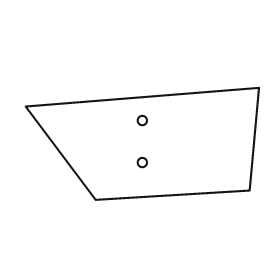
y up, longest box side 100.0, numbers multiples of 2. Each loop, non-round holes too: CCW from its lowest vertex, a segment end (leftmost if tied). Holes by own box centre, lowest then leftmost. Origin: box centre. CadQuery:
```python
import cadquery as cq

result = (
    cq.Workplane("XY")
    .moveTo(-20.0, -24.0)
    .lineTo(46.0, -20.0)
    .lineTo(50.0, 24.0)
    .lineTo(-50.0, 16.0)
    .close()
    .moveTo(0.0, -8.0)
    .circle(2.0)
    .moveTo(0.0, 10.0)
    .circle(2.0)
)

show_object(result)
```